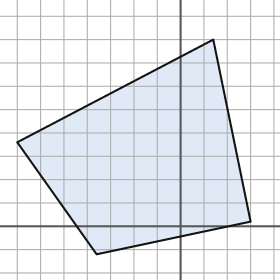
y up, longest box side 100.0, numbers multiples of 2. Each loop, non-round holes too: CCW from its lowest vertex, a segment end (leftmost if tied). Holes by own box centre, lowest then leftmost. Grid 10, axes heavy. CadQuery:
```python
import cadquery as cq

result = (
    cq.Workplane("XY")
    .moveTo(-36.0, -12.0)
    .lineTo(30.0, 2.0)
    .lineTo(14.0, 80.0)
    .lineTo(-70.0, 36.0)
    .close()
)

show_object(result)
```